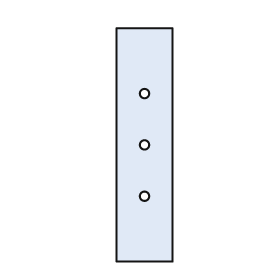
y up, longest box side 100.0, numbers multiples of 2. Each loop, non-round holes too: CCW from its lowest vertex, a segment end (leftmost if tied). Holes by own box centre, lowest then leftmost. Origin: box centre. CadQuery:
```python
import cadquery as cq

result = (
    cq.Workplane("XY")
    .moveTo(-12.0, -50.0)
    .lineTo(12.0, -50.0)
    .lineTo(12.0, 50.0)
    .lineTo(-12.0, 50.0)
    .close()
    .moveTo(0.0, -22.0)
    .circle(2.0)
    .moveTo(0.0, 0.0)
    .circle(2.0)
    .moveTo(0.0, 22.0)
    .circle(2.0)
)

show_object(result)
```